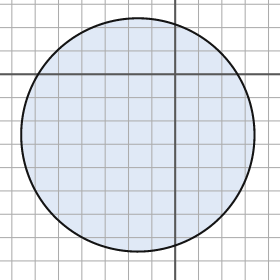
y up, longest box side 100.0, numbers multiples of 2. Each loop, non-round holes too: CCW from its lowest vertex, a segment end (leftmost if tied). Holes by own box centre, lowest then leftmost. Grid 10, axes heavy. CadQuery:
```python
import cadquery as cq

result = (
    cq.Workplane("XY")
    .moveTo(-16.0, -26.0)
    .circle(50.0)
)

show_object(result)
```